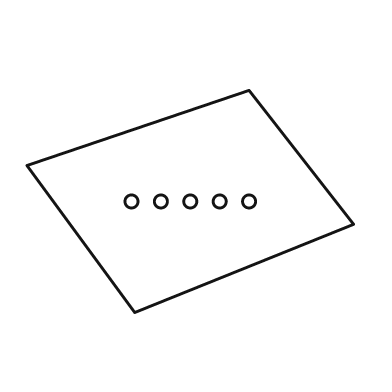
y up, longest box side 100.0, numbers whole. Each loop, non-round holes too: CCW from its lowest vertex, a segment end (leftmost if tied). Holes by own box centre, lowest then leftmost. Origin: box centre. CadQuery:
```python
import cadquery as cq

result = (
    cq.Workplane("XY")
    .moveTo(-17.0, -34.0)
    .lineTo(50.0, -7.0)
    .lineTo(18.0, 34.0)
    .lineTo(-50.0, 11.0)
    .close()
    .moveTo(-18.0, 0.0)
    .circle(2.0)
    .moveTo(-9.0, 0.0)
    .circle(2.0)
    .moveTo(0.0, 0.0)
    .circle(2.0)
    .moveTo(9.0, 0.0)
    .circle(2.0)
    .moveTo(18.0, 0.0)
    .circle(2.0)
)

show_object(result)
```